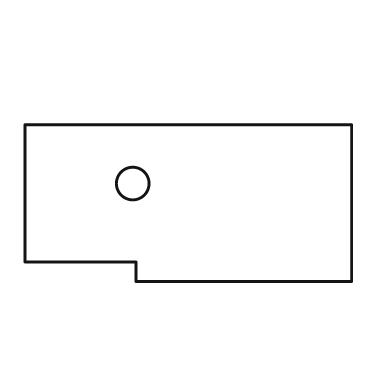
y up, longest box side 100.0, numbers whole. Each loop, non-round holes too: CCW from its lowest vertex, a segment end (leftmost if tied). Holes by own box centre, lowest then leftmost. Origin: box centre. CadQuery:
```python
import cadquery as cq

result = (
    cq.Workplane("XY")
    .moveTo(-16.0, -24.0)
    .lineTo(50.0, -24.0)
    .lineTo(50.0, 24.0)
    .lineTo(-50.0, 24.0)
    .lineTo(-50.0, -18.0)
    .lineTo(-16.0, -18.0)
    .close()
    .moveTo(-17.0, 6.0)
    .circle(5.0)
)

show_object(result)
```